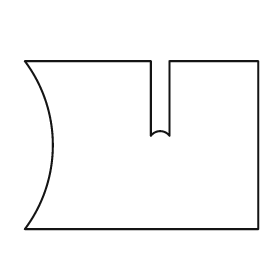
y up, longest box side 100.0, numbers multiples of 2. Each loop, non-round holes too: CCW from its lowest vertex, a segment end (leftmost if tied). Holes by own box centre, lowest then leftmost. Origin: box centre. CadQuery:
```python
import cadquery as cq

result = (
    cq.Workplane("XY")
    .moveTo(-50.0, -36.0)
    .lineTo(50.0, -36.0)
    .lineTo(50.0, 36.0)
    .lineTo(12.0, 36.0)
    .lineTo(12.0, 4.0)
    .threePointArc((8.0, 6.0), (4.0, 4.0))
    .lineTo(4.0, 36.0)
    .lineTo(-50.0, 36.0)
    .threePointArc((-38.0, 0.0), (-50.0, -36.0))
    .close()
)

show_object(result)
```